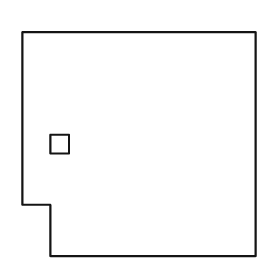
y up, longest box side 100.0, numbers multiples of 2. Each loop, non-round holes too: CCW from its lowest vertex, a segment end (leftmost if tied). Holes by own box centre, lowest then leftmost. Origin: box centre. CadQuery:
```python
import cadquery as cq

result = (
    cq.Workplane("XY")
    .moveTo(-38.0, -48.0)
    .lineTo(50.0, -48.0)
    .lineTo(50.0, 48.0)
    .lineTo(-50.0, 48.0)
    .lineTo(-50.0, -26.0)
    .lineTo(-38.0, -26.0)
    .close()
    .moveTo(-38.0, -4.0)
    .lineTo(-30.0, -4.0)
    .lineTo(-30.0, 4.0)
    .lineTo(-38.0, 4.0)
    .close()
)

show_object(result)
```